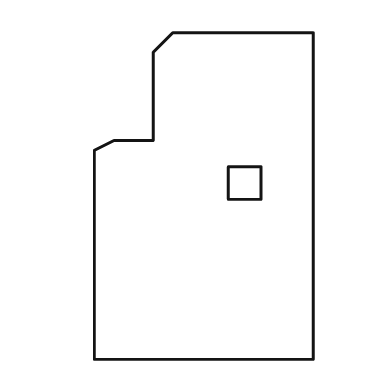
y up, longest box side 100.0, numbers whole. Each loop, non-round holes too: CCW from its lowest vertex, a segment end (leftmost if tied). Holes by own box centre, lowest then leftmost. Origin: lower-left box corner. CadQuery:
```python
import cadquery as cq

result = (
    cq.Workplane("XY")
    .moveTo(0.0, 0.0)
    .lineTo(67.0, 0.0)
    .lineTo(67.0, 100.0)
    .lineTo(24.0, 100.0)
    .lineTo(18.0, 94.0)
    .lineTo(18.0, 67.0)
    .lineTo(6.0, 67.0)
    .lineTo(0.0, 64.0)
    .close()
    .moveTo(41.0, 49.0)
    .lineTo(51.0, 49.0)
    .lineTo(51.0, 59.0)
    .lineTo(41.0, 59.0)
    .close()
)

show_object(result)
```